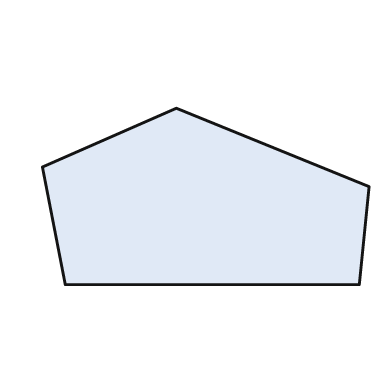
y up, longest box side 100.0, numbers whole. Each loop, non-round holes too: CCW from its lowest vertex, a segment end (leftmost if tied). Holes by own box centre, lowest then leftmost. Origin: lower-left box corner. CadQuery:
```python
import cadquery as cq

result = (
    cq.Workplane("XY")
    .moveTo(7.0, 0.0)
    .lineTo(97.0, 0.0)
    .lineTo(100.0, 30.0)
    .lineTo(41.0, 54.0)
    .lineTo(0.0, 36.0)
    .close()
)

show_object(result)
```